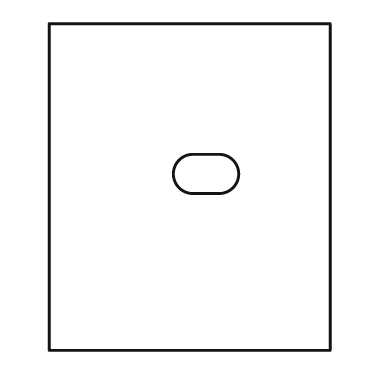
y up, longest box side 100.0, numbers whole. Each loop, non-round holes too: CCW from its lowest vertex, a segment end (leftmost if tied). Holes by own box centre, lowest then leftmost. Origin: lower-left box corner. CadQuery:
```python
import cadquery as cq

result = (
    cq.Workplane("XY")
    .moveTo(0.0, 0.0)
    .lineTo(86.0, 0.0)
    .lineTo(86.0, 100.0)
    .lineTo(0.0, 100.0)
    .close()
    .moveTo(44.0, 48.0)
    .lineTo(52.0, 48.0)
    .threePointArc((58.0, 54.0), (52.0, 60.0))
    .lineTo(44.0, 60.0)
    .threePointArc((38.0, 54.0), (44.0, 48.0))
    .close()
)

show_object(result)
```